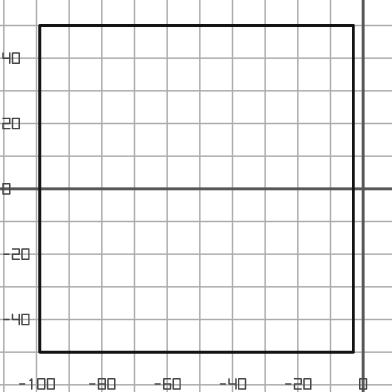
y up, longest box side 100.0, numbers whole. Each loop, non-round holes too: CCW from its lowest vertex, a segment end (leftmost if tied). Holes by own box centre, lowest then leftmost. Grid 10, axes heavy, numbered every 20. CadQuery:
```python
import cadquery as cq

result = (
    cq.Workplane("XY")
    .moveTo(-99.0, -50.0)
    .lineTo(-3.0, -50.0)
    .lineTo(-3.0, 50.0)
    .lineTo(-99.0, 50.0)
    .close()
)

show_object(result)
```